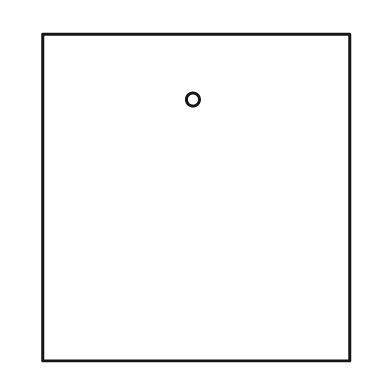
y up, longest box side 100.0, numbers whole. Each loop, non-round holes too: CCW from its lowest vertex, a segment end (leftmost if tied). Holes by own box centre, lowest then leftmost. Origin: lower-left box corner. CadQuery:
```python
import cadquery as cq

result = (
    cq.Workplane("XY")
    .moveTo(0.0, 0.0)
    .lineTo(94.0, 0.0)
    .lineTo(94.0, 100.0)
    .lineTo(0.0, 100.0)
    .close()
    .moveTo(46.0, 80.0)
    .circle(2.0)
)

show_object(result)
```